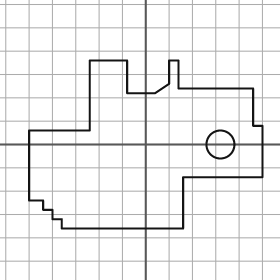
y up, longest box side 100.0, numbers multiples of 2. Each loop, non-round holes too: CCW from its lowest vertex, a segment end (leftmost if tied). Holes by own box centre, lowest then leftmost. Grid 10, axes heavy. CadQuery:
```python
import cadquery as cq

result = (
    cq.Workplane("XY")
    .moveTo(-36.0, -36.0)
    .lineTo(16.0, -36.0)
    .lineTo(16.0, -14.0)
    .lineTo(50.0, -14.0)
    .lineTo(50.0, 8.0)
    .lineTo(46.0, 8.0)
    .lineTo(46.0, 24.0)
    .lineTo(14.0, 24.0)
    .lineTo(14.0, 36.0)
    .lineTo(10.0, 36.0)
    .lineTo(10.0, 26.0)
    .lineTo(4.0, 22.0)
    .lineTo(-8.0, 22.0)
    .lineTo(-8.0, 36.0)
    .lineTo(-24.0, 36.0)
    .lineTo(-24.0, 6.0)
    .lineTo(-50.0, 6.0)
    .lineTo(-50.0, -24.0)
    .lineTo(-44.0, -24.0)
    .lineTo(-44.0, -28.0)
    .lineTo(-40.0, -28.0)
    .lineTo(-40.0, -32.0)
    .lineTo(-36.0, -32.0)
    .close()
    .moveTo(32.0, 0.0)
    .circle(6.0)
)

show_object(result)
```